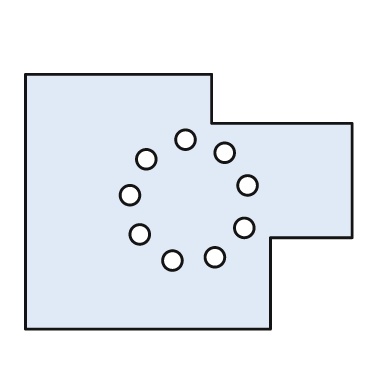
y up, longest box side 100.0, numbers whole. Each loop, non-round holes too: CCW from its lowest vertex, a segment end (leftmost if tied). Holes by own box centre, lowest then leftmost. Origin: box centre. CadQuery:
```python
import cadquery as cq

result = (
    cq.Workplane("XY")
    .moveTo(-50.0, -39.0)
    .lineTo(25.0, -39.0)
    .lineTo(25.0, -11.0)
    .lineTo(50.0, -11.0)
    .lineTo(50.0, 24.0)
    .lineTo(7.0, 24.0)
    .lineTo(7.0, 39.0)
    .lineTo(-50.0, 39.0)
    .close()
    .moveTo(-5.0, -18.0)
    .circle(3.0)
    .moveTo(8.0, -17.0)
    .circle(3.0)
    .moveTo(-15.0, -10.0)
    .circle(3.0)
    .moveTo(17.0, -8.0)
    .circle(3.0)
    .moveTo(-18.0, 2.0)
    .circle(3.0)
    .moveTo(18.0, 5.0)
    .circle(3.0)
    .moveTo(-13.0, 13.0)
    .circle(3.0)
    .moveTo(11.0, 15.0)
    .circle(3.0)
    .moveTo(-1.0, 19.0)
    .circle(3.0)
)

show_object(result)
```